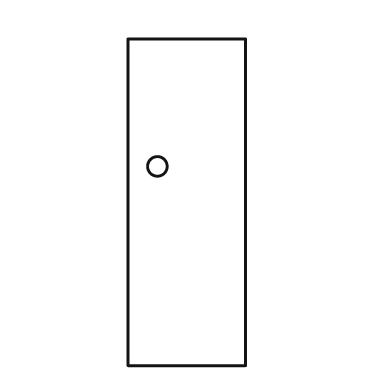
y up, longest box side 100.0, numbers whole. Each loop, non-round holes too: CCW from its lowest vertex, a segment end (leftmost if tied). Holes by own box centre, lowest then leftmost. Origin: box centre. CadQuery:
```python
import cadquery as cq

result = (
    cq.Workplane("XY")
    .moveTo(-18.0, -50.0)
    .lineTo(18.0, -50.0)
    .lineTo(18.0, 50.0)
    .lineTo(-18.0, 50.0)
    .close()
    .moveTo(-9.0, 11.0)
    .circle(3.0)
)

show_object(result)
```